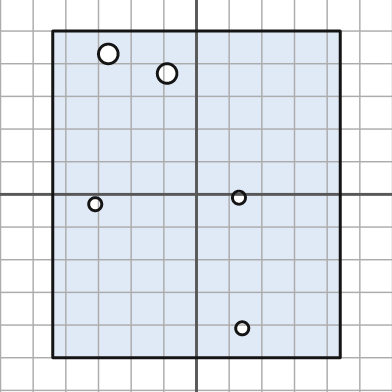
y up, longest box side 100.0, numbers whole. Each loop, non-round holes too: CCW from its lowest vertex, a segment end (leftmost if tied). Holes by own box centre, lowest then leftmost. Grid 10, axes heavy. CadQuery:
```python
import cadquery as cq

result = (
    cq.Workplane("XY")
    .moveTo(-44.0, -50.0)
    .lineTo(44.0, -50.0)
    .lineTo(44.0, 50.0)
    .lineTo(-44.0, 50.0)
    .close()
    .moveTo(14.0, -41.0)
    .circle(2.0)
    .moveTo(-31.0, -3.0)
    .circle(2.0)
    .moveTo(13.0, -1.0)
    .circle(2.0)
    .moveTo(-9.0, 37.0)
    .circle(3.0)
    .moveTo(-27.0, 43.0)
    .circle(3.0)
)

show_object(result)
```